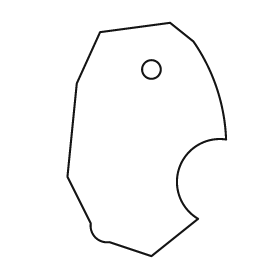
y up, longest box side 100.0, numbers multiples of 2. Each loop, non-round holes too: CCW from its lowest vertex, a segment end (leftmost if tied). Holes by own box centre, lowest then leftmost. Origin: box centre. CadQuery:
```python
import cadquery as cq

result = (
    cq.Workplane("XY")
    .moveTo(2.0, -50.0)
    .lineTo(22.0, -34.0)
    .threePointArc((14.0, -12.0), (34.0, 0.0))
    .threePointArc((30.0, 22.0), (20.0, 42.0))
    .lineTo(10.0, 50.0)
    .lineTo(-20.0, 46.0)
    .lineTo(-30.0, 24.0)
    .lineTo(-34.0, -16.0)
    .lineTo(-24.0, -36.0)
    .threePointArc((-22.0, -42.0), (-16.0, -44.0))
    .close()
    .moveTo(2.0, 30.0)
    .circle(4.0)
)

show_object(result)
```